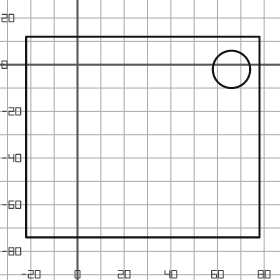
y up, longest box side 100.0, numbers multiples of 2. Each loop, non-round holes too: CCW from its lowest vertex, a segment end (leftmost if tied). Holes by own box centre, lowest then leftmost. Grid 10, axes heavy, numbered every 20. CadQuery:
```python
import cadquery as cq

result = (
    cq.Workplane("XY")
    .moveTo(-22.0, -74.0)
    .lineTo(78.0, -74.0)
    .lineTo(78.0, 12.0)
    .lineTo(-22.0, 12.0)
    .close()
    .moveTo(66.0, -2.0)
    .circle(8.0)
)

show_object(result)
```